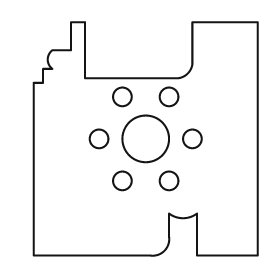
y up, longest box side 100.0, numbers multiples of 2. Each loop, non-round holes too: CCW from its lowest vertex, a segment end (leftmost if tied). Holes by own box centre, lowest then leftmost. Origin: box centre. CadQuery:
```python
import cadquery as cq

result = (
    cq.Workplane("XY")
    .moveTo(-48.0, -50.0)
    .lineTo(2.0, -50.0)
    .threePointArc((8.0, -48.0), (10.0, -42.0))
    .lineTo(10.0, -32.0)
    .threePointArc((16.0, -34.0), (22.0, -32.0))
    .lineTo(22.0, -50.0)
    .lineTo(48.0, -50.0)
    .lineTo(48.0, 50.0)
    .lineTo(20.0, 50.0)
    .lineTo(20.0, 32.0)
    .threePointArc((18.0, 28.0), (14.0, 26.0))
    .lineTo(-26.0, 26.0)
    .lineTo(-26.0, 50.0)
    .lineTo(-32.0, 50.0)
    .lineTo(-32.0, 38.0)
    .lineTo(-40.0, 38.0)
    .threePointArc((-42.0, 34.0), (-40.0, 30.0))
    .lineTo(-44.0, 30.0)
    .lineTo(-44.0, 24.0)
    .lineTo(-48.0, 24.0)
    .close()
    .moveTo(-10.0, -18.0)
    .circle(4.0)
    .moveTo(10.0, -18.0)
    .circle(4.0)
    .moveTo(-20.0, 0.0)
    .circle(4.0)
    .moveTo(0.0, 0.0)
    .circle(10.0)
    .moveTo(20.0, 0.0)
    .circle(4.0)
    .moveTo(-10.0, 18.0)
    .circle(4.0)
    .moveTo(10.0, 18.0)
    .circle(4.0)
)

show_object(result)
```